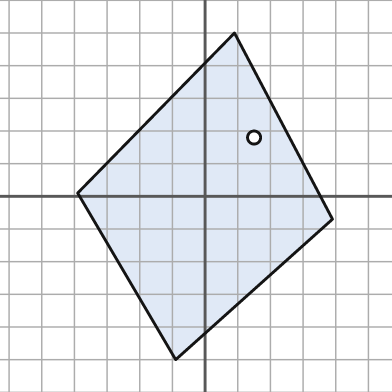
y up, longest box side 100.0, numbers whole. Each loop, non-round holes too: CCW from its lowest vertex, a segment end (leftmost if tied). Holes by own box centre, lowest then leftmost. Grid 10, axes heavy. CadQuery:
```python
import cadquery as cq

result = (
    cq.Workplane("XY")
    .moveTo(-9.0, -50.0)
    .lineTo(39.0, -7.0)
    .lineTo(9.0, 50.0)
    .lineTo(-39.0, 1.0)
    .close()
    .moveTo(15.0, 18.0)
    .circle(2.0)
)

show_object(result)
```